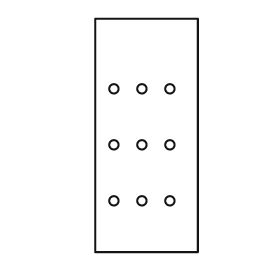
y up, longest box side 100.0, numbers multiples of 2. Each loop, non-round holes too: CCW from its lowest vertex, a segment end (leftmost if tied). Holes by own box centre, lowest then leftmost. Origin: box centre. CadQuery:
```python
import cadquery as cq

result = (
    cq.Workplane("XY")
    .moveTo(-22.0, -50.0)
    .lineTo(22.0, -50.0)
    .lineTo(22.0, 50.0)
    .lineTo(-22.0, 50.0)
    .close()
    .moveTo(-14.0, -28.0)
    .circle(2.0)
    .moveTo(-2.0, -28.0)
    .circle(2.0)
    .moveTo(10.0, -28.0)
    .circle(2.0)
    .moveTo(-14.0, -4.0)
    .circle(2.0)
    .moveTo(-2.0, -4.0)
    .circle(2.0)
    .moveTo(10.0, -4.0)
    .circle(2.0)
    .moveTo(-14.0, 20.0)
    .circle(2.0)
    .moveTo(-2.0, 20.0)
    .circle(2.0)
    .moveTo(10.0, 20.0)
    .circle(2.0)
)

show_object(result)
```